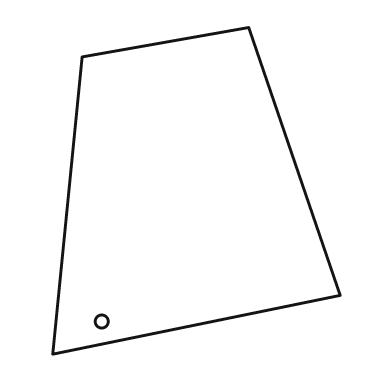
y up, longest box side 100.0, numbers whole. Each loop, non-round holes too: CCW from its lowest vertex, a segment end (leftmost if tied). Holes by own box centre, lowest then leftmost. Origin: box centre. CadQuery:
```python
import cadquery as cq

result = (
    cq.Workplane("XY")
    .moveTo(-44.0, -50.0)
    .lineTo(44.0, -32.0)
    .lineTo(16.0, 50.0)
    .lineTo(-35.0, 41.0)
    .close()
    .moveTo(-29.0, -40.0)
    .circle(2.0)
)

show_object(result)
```